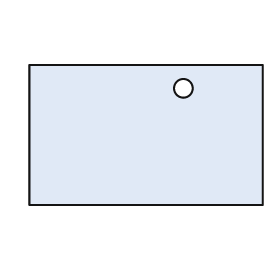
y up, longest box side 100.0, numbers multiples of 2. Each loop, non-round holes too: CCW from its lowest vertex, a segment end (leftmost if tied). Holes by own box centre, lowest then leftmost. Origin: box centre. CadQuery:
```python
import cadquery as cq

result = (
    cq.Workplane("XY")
    .moveTo(-50.0, -30.0)
    .lineTo(50.0, -30.0)
    .lineTo(50.0, 30.0)
    .lineTo(-50.0, 30.0)
    .close()
    .moveTo(16.0, 20.0)
    .circle(4.0)
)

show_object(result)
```